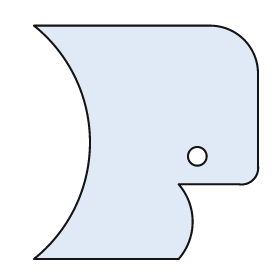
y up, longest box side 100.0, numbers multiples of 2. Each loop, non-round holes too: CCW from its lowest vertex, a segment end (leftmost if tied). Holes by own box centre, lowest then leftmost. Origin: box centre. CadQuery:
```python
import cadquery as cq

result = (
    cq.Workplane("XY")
    .moveTo(-48.0, -50.0)
    .lineTo(14.0, -50.0)
    .threePointArc((20.0, -34.0), (14.0, -18.0))
    .lineTo(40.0, -18.0)
    .threePointArc((46.0, -16.0), (48.0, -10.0))
    .lineTo(48.0, 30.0)
    .threePointArc((42.0, 44.0), (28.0, 50.0))
    .lineTo(-48.0, 50.0)
    .threePointArc((-24.0, 0.0), (-48.0, -50.0))
    .close()
    .moveTo(22.0, -6.0)
    .circle(4.0)
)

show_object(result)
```